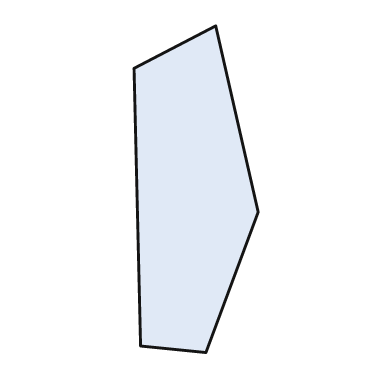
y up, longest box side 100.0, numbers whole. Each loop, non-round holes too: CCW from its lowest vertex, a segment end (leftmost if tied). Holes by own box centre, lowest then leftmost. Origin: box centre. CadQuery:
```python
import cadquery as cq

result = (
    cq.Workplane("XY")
    .moveTo(3.0, -50.0)
    .lineTo(19.0, -7.0)
    .lineTo(6.0, 50.0)
    .lineTo(-19.0, 37.0)
    .lineTo(-17.0, -48.0)
    .close()
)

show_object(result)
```